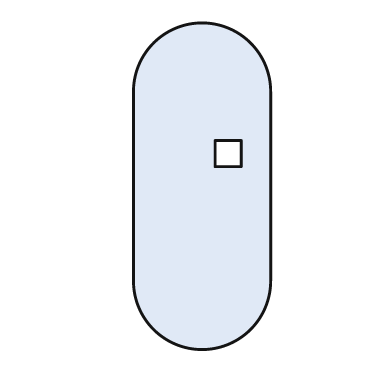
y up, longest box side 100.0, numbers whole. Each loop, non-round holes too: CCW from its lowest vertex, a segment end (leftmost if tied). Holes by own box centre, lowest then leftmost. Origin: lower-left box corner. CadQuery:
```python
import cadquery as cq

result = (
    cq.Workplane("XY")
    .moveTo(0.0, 21.0)
    .threePointArc((21.0, 0.0), (42.0, 21.0))
    .lineTo(42.0, 79.0)
    .threePointArc((21.0, 100.0), (0.0, 79.0))
    .close()
    .moveTo(25.0, 56.0)
    .lineTo(33.0, 56.0)
    .lineTo(33.0, 64.0)
    .lineTo(25.0, 64.0)
    .close()
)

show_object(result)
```